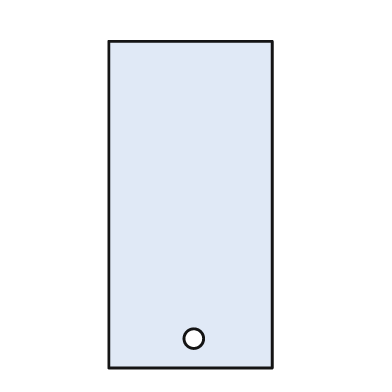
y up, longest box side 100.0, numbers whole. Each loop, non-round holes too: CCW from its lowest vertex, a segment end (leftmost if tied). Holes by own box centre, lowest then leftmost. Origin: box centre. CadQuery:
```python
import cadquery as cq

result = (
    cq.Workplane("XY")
    .moveTo(-25.0, -50.0)
    .lineTo(25.0, -50.0)
    .lineTo(25.0, 50.0)
    .lineTo(-25.0, 50.0)
    .close()
    .moveTo(1.0, -41.0)
    .circle(3.0)
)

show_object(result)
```